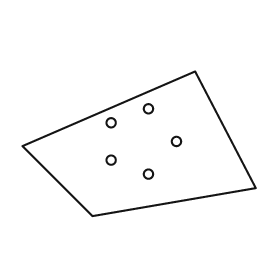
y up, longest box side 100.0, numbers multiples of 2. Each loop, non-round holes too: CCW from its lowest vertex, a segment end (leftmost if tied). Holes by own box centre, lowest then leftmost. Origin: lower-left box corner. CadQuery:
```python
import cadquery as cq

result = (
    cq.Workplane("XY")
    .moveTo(30.0, 0.0)
    .lineTo(100.0, 12.0)
    .lineTo(74.0, 62.0)
    .lineTo(0.0, 30.0)
    .close()
    .moveTo(54.0, 18.0)
    .circle(2.0)
    .moveTo(38.0, 24.0)
    .circle(2.0)
    .moveTo(66.0, 32.0)
    .circle(2.0)
    .moveTo(38.0, 40.0)
    .circle(2.0)
    .moveTo(54.0, 46.0)
    .circle(2.0)
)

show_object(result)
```